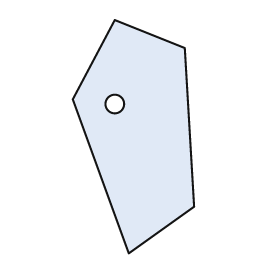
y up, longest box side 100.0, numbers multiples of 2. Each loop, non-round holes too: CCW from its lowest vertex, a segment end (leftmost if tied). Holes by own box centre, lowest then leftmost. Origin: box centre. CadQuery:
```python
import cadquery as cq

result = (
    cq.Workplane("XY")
    .moveTo(-2.0, -50.0)
    .lineTo(26.0, -30.0)
    .lineTo(22.0, 38.0)
    .lineTo(-8.0, 50.0)
    .lineTo(-26.0, 16.0)
    .close()
    .moveTo(-8.0, 14.0)
    .circle(4.0)
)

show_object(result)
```